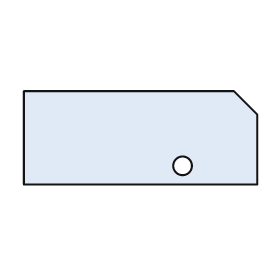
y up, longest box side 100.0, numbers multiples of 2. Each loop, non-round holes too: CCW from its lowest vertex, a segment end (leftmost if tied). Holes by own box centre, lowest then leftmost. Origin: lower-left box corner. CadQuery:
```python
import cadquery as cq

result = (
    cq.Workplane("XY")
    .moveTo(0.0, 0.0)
    .lineTo(100.0, 0.0)
    .lineTo(100.0, 30.0)
    .lineTo(90.0, 40.0)
    .lineTo(0.0, 40.0)
    .close()
    .moveTo(68.0, 8.0)
    .circle(4.0)
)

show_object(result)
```